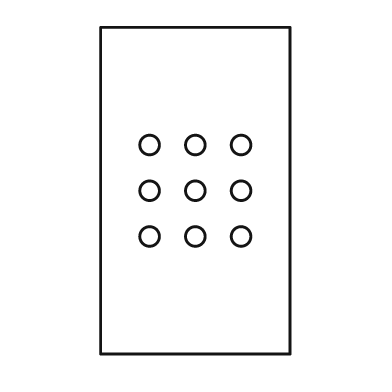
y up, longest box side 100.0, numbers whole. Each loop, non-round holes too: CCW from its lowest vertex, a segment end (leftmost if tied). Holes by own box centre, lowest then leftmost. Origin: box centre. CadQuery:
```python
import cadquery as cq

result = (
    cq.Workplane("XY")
    .moveTo(-29.0, -50.0)
    .lineTo(29.0, -50.0)
    .lineTo(29.0, 50.0)
    .lineTo(-29.0, 50.0)
    .close()
    .moveTo(-14.0, -14.0)
    .circle(3.0)
    .moveTo(0.0, -14.0)
    .circle(3.0)
    .moveTo(14.0, -14.0)
    .circle(3.0)
    .moveTo(-14.0, 0.0)
    .circle(3.0)
    .moveTo(0.0, 0.0)
    .circle(3.0)
    .moveTo(14.0, 0.0)
    .circle(3.0)
    .moveTo(-14.0, 14.0)
    .circle(3.0)
    .moveTo(0.0, 14.0)
    .circle(3.0)
    .moveTo(14.0, 14.0)
    .circle(3.0)
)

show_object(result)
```